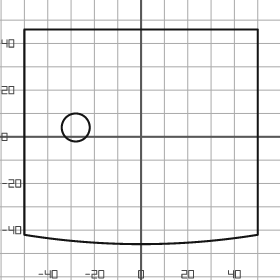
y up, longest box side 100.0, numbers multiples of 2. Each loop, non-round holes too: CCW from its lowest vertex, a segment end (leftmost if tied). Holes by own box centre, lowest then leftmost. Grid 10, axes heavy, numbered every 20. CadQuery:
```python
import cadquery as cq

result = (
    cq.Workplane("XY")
    .moveTo(-50.0, -42.0)
    .threePointArc((0.0, -46.0), (50.0, -42.0))
    .lineTo(50.0, 46.0)
    .lineTo(-50.0, 46.0)
    .close()
    .moveTo(-28.0, 4.0)
    .circle(6.0)
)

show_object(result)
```